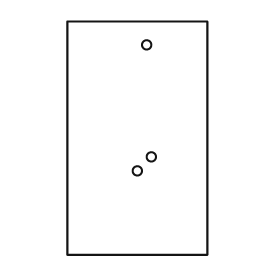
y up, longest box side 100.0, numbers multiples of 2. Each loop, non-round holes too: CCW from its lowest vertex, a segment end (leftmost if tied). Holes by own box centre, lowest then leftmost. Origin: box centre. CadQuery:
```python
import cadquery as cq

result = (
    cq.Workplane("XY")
    .moveTo(-30.0, -50.0)
    .lineTo(30.0, -50.0)
    .lineTo(30.0, 50.0)
    .lineTo(-30.0, 50.0)
    .close()
    .moveTo(0.0, -14.0)
    .circle(2.0)
    .moveTo(6.0, -8.0)
    .circle(2.0)
    .moveTo(4.0, 40.0)
    .circle(2.0)
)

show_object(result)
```